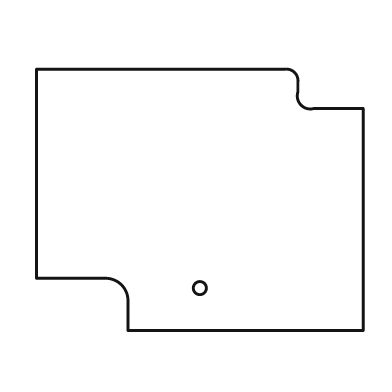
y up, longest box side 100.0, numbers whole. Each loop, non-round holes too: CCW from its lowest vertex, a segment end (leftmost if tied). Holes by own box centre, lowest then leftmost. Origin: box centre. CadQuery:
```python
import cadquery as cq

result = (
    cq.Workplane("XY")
    .moveTo(-22.0, -40.0)
    .lineTo(50.0, -40.0)
    .lineTo(50.0, 28.0)
    .lineTo(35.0, 28.0)
    .threePointArc((31.0, 29.0), (30.0, 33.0))
    .lineTo(30.0, 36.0)
    .threePointArc((29.0, 39.0), (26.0, 40.0))
    .lineTo(-50.0, 40.0)
    .lineTo(-50.0, -24.0)
    .lineTo(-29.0, -24.0)
    .threePointArc((-24.0, -26.0), (-22.0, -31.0))
    .close()
    .moveTo(0.0, -27.0)
    .circle(2.0)
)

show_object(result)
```